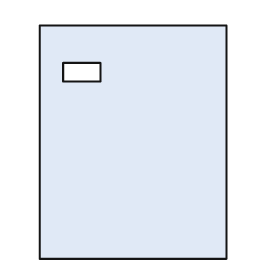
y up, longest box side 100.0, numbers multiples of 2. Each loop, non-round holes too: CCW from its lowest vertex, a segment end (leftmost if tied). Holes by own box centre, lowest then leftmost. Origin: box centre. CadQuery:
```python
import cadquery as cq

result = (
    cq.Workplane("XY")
    .moveTo(-40.0, -50.0)
    .lineTo(40.0, -50.0)
    .lineTo(40.0, 50.0)
    .lineTo(-40.0, 50.0)
    .close()
    .moveTo(-30.0, 26.0)
    .lineTo(-14.0, 26.0)
    .lineTo(-14.0, 34.0)
    .lineTo(-30.0, 34.0)
    .close()
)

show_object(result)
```